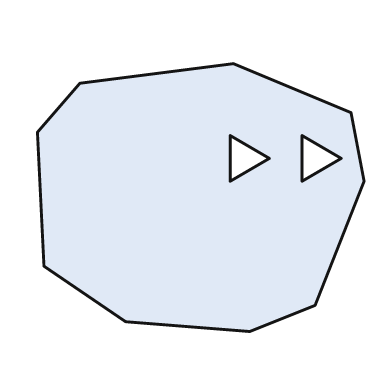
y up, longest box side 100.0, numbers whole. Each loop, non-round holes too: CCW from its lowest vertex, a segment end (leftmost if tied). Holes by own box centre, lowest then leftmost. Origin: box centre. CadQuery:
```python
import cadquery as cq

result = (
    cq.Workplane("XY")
    .moveTo(15.0, -41.0)
    .lineTo(35.0, -33.0)
    .lineTo(50.0, 5.0)
    .lineTo(46.0, 26.0)
    .lineTo(10.0, 41.0)
    .lineTo(-37.0, 35.0)
    .lineTo(-50.0, 20.0)
    .lineTo(-48.0, -21.0)
    .lineTo(-23.0, -38.0)
    .close()
    .moveTo(9.0, 5.0)
    .lineTo(21.0, 12.0)
    .lineTo(9.0, 19.0)
    .close()
    .moveTo(31.0, 5.0)
    .lineTo(43.0, 12.0)
    .lineTo(31.0, 19.0)
    .close()
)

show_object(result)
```